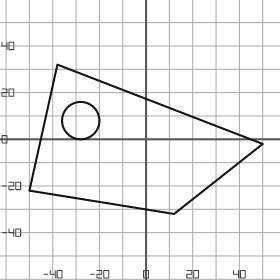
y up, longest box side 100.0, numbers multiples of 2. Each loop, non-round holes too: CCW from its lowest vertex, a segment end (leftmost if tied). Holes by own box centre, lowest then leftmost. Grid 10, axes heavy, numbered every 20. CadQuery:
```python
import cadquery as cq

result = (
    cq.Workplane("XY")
    .moveTo(12.0, -32.0)
    .lineTo(50.0, -2.0)
    .lineTo(-38.0, 32.0)
    .lineTo(-50.0, -22.0)
    .close()
    .moveTo(-28.0, 8.0)
    .circle(8.0)
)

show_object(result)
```